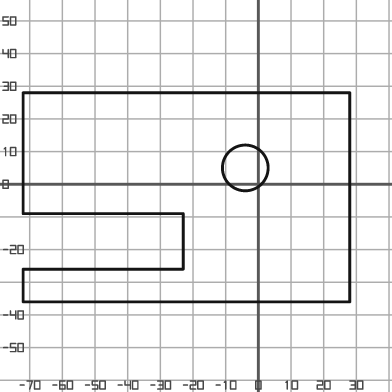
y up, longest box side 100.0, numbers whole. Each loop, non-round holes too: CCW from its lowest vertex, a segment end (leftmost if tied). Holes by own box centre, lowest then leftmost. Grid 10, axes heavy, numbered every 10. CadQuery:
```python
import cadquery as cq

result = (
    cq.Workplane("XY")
    .moveTo(-72.0, -36.0)
    .lineTo(28.0, -36.0)
    .lineTo(28.0, 28.0)
    .lineTo(-72.0, 28.0)
    .lineTo(-72.0, -9.0)
    .lineTo(-23.0, -9.0)
    .lineTo(-23.0, -26.0)
    .lineTo(-72.0, -26.0)
    .close()
    .moveTo(-4.0, 5.0)
    .circle(7.0)
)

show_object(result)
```